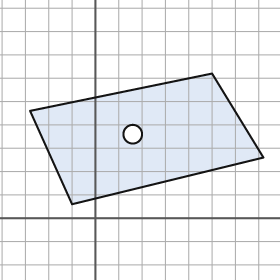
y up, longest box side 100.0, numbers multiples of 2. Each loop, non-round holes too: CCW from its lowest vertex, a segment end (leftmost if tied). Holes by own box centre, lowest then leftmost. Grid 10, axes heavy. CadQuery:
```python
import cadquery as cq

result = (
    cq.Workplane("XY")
    .moveTo(-10.0, 6.0)
    .lineTo(72.0, 26.0)
    .lineTo(50.0, 62.0)
    .lineTo(-28.0, 46.0)
    .close()
    .moveTo(16.0, 36.0)
    .circle(4.0)
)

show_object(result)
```